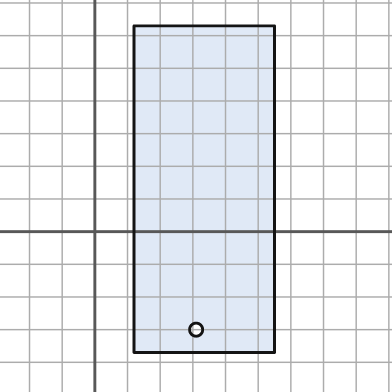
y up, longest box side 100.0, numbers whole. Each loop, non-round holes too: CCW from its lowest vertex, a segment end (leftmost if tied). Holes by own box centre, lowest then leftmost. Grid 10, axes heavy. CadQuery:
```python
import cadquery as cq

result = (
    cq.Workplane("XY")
    .moveTo(12.0, -37.0)
    .lineTo(55.0, -37.0)
    .lineTo(55.0, 63.0)
    .lineTo(12.0, 63.0)
    .close()
    .moveTo(31.0, -30.0)
    .circle(2.0)
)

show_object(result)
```